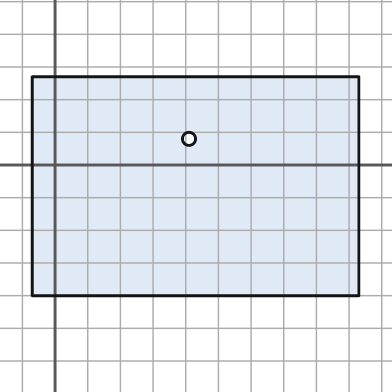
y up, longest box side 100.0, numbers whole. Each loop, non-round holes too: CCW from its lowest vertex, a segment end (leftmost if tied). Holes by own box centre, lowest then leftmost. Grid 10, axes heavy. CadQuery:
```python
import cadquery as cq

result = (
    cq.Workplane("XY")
    .moveTo(-7.0, -40.0)
    .lineTo(93.0, -40.0)
    .lineTo(93.0, 27.0)
    .lineTo(-7.0, 27.0)
    .close()
    .moveTo(41.0, 8.0)
    .circle(2.0)
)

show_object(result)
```